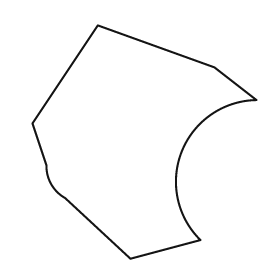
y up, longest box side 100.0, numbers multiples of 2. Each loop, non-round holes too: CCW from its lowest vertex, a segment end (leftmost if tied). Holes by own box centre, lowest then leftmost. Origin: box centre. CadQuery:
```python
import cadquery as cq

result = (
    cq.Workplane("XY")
    .moveTo(-6.0, -50.0)
    .lineTo(24.0, -42.0)
    .threePointArc((16.0, -4.0), (48.0, 18.0))
    .lineTo(30.0, 32.0)
    .lineTo(-20.0, 50.0)
    .lineTo(-48.0, 8.0)
    .lineTo(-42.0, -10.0)
    .threePointArc((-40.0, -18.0), (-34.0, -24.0))
    .close()
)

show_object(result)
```